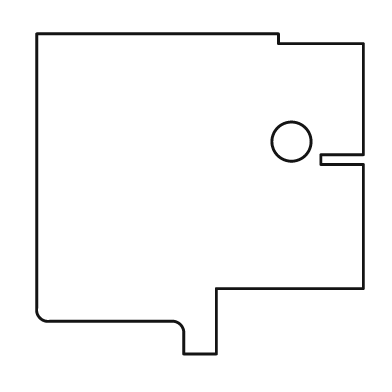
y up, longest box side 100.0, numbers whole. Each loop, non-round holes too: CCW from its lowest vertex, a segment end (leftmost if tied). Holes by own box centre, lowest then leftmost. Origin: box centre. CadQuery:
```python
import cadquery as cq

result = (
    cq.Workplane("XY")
    .moveTo(-5.0, -49.0)
    .lineTo(5.0, -49.0)
    .lineTo(5.0, -29.0)
    .lineTo(50.0, -29.0)
    .lineTo(50.0, 9.0)
    .lineTo(37.0, 9.0)
    .lineTo(37.0, 12.0)
    .lineTo(50.0, 12.0)
    .lineTo(50.0, 46.0)
    .lineTo(24.0, 46.0)
    .lineTo(24.0, 49.0)
    .lineTo(-50.0, 49.0)
    .lineTo(-50.0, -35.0)
    .threePointArc((-49.0, -38.0), (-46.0, -39.0))
    .lineTo(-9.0, -39.0)
    .threePointArc((-6.0, -40.0), (-5.0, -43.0))
    .close()
    .moveTo(28.0, 16.0)
    .circle(6.0)
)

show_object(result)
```